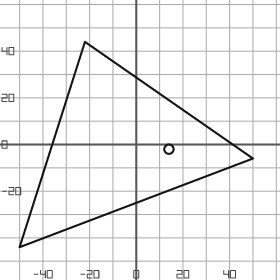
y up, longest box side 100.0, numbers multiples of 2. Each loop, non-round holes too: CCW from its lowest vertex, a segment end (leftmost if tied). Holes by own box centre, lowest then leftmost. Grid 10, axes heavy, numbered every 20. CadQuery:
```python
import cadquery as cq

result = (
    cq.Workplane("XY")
    .moveTo(-50.0, -44.0)
    .lineTo(50.0, -6.0)
    .lineTo(-22.0, 44.0)
    .close()
    .moveTo(14.0, -2.0)
    .circle(2.0)
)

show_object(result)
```